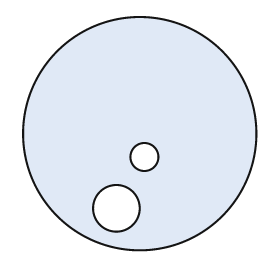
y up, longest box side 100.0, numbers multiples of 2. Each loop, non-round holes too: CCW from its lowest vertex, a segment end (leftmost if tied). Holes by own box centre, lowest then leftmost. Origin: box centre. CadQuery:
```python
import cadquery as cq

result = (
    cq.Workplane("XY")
    .moveTo(0.0, 0.0)
    .circle(50.0)
    .moveTo(-10.0, -32.0)
    .circle(10.0)
    .moveTo(2.0, -10.0)
    .circle(6.0)
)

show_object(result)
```